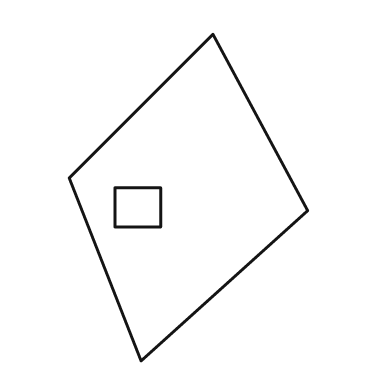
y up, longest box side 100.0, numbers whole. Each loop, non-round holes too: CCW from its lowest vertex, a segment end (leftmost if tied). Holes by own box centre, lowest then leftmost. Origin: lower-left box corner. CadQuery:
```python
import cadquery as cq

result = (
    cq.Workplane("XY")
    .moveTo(22.0, 0.0)
    .lineTo(73.0, 46.0)
    .lineTo(44.0, 100.0)
    .lineTo(0.0, 56.0)
    .close()
    .moveTo(14.0, 41.0)
    .lineTo(28.0, 41.0)
    .lineTo(28.0, 53.0)
    .lineTo(14.0, 53.0)
    .close()
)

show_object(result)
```